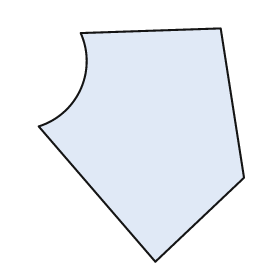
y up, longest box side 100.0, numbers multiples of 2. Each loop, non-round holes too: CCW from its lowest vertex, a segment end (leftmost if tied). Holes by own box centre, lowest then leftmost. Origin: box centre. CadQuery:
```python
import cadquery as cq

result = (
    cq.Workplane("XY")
    .moveTo(6.0, -50.0)
    .lineTo(44.0, -14.0)
    .lineTo(34.0, 50.0)
    .lineTo(-26.0, 48.0)
    .threePointArc((-26.0, 24.0), (-44.0, 8.0))
    .close()
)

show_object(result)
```